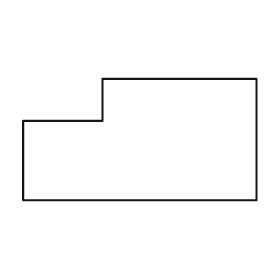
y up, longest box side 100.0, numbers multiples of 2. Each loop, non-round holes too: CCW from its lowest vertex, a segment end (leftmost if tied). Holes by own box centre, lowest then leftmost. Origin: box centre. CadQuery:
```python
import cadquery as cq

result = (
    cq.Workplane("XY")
    .moveTo(-50.0, -26.0)
    .lineTo(50.0, -26.0)
    .lineTo(50.0, 26.0)
    .lineTo(-16.0, 26.0)
    .lineTo(-16.0, 8.0)
    .lineTo(-50.0, 8.0)
    .close()
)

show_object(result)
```